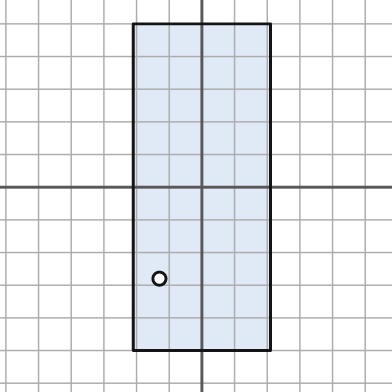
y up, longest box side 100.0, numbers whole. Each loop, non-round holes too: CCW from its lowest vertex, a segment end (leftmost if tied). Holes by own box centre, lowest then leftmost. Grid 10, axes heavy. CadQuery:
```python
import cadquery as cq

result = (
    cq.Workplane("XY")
    .moveTo(-21.0, -50.0)
    .lineTo(21.0, -50.0)
    .lineTo(21.0, 50.0)
    .lineTo(-21.0, 50.0)
    .close()
    .moveTo(-13.0, -28.0)
    .circle(2.0)
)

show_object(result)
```